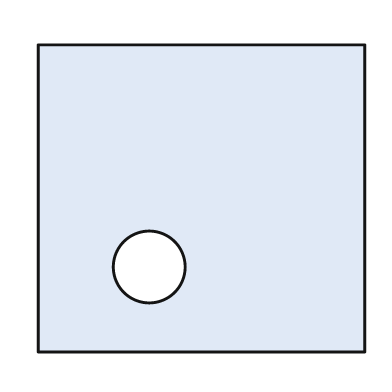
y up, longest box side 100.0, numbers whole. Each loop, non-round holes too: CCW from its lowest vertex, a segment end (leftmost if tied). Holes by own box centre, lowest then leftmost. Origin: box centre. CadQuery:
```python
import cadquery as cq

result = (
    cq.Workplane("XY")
    .moveTo(-50.0, -47.0)
    .lineTo(50.0, -47.0)
    .lineTo(50.0, 47.0)
    .lineTo(-50.0, 47.0)
    .close()
    .moveTo(-16.0, -21.0)
    .circle(11.0)
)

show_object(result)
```